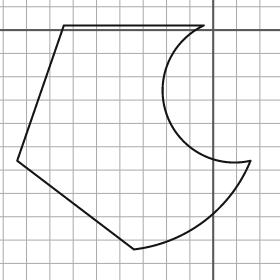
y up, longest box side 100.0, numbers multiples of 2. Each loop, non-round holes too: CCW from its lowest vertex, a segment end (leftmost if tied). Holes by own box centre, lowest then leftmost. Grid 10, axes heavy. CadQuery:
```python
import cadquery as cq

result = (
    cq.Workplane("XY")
    .moveTo(-34.0, -94.0)
    .threePointArc((-4.0, -82.0), (16.0, -56.0))
    .threePointArc((-20.0, -36.0), (-4.0, 2.0))
    .lineTo(-64.0, 2.0)
    .lineTo(-84.0, -56.0)
    .close()
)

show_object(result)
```